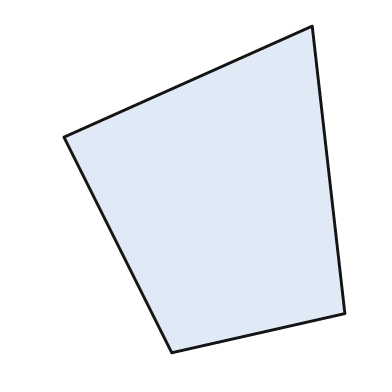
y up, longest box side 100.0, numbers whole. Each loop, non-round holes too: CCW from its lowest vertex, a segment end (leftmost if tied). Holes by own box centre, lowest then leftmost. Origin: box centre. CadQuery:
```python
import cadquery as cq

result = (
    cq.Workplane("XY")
    .moveTo(-10.0, -50.0)
    .lineTo(43.0, -38.0)
    .lineTo(33.0, 50.0)
    .lineTo(-43.0, 16.0)
    .close()
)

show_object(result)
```